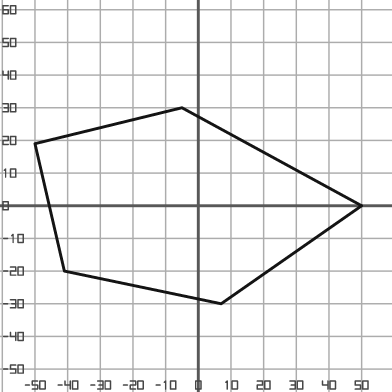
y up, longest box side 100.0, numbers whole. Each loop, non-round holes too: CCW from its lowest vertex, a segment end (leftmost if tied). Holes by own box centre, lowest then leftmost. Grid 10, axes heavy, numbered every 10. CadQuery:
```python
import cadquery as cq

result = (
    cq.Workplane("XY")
    .moveTo(7.0, -30.0)
    .lineTo(50.0, 0.0)
    .lineTo(-5.0, 30.0)
    .lineTo(-50.0, 19.0)
    .lineTo(-41.0, -20.0)
    .close()
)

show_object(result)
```